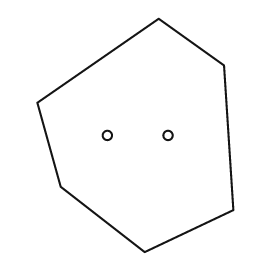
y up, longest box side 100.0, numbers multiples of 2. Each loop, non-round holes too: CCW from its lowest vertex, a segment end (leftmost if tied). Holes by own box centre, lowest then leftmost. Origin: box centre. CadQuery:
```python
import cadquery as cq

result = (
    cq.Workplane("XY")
    .moveTo(4.0, -50.0)
    .lineTo(42.0, -32.0)
    .lineTo(38.0, 30.0)
    .lineTo(10.0, 50.0)
    .lineTo(-42.0, 14.0)
    .lineTo(-32.0, -22.0)
    .close()
    .moveTo(-12.0, 0.0)
    .circle(2.0)
    .moveTo(14.0, 0.0)
    .circle(2.0)
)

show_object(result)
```